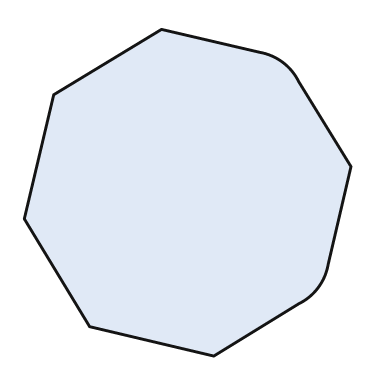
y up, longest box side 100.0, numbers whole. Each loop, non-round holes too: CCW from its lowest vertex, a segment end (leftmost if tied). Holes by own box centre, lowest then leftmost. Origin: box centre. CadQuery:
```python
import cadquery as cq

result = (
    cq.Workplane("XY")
    .moveTo(8.0, -50.0)
    .lineTo(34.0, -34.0)
    .threePointArc((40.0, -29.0), (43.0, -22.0))
    .lineTo(50.0, 8.0)
    .lineTo(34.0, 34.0)
    .threePointArc((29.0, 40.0), (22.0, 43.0))
    .lineTo(-8.0, 50.0)
    .lineTo(-41.0, 30.0)
    .lineTo(-50.0, -8.0)
    .lineTo(-30.0, -41.0)
    .close()
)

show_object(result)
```